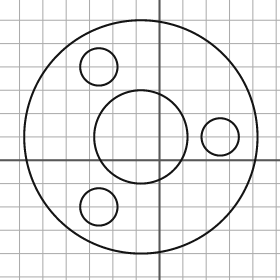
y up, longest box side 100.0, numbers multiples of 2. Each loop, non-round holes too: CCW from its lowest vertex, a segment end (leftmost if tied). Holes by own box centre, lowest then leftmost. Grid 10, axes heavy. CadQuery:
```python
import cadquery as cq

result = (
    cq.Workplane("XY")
    .moveTo(-8.0, 10.0)
    .circle(50.0)
    .moveTo(-26.0, -20.0)
    .circle(8.0)
    .moveTo(-8.0, 10.0)
    .circle(20.0)
    .moveTo(26.0, 10.0)
    .circle(8.0)
    .moveTo(-26.0, 40.0)
    .circle(8.0)
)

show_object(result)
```